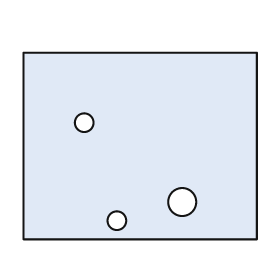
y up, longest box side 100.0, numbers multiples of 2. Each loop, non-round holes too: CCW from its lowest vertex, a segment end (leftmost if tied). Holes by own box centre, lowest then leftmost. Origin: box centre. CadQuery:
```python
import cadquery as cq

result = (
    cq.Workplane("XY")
    .moveTo(-50.0, -40.0)
    .lineTo(50.0, -40.0)
    .lineTo(50.0, 40.0)
    .lineTo(-50.0, 40.0)
    .close()
    .moveTo(-10.0, -32.0)
    .circle(4.0)
    .moveTo(18.0, -24.0)
    .circle(6.0)
    .moveTo(-24.0, 10.0)
    .circle(4.0)
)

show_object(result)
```